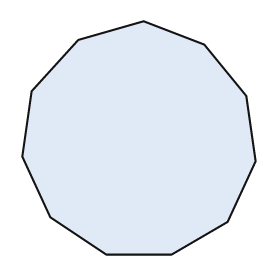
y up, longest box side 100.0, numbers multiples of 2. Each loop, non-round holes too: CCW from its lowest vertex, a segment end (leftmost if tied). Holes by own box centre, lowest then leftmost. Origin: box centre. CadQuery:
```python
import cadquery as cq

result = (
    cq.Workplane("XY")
    .moveTo(-14.0, -50.0)
    .lineTo(14.0, -50.0)
    .lineTo(38.0, -36.0)
    .lineTo(50.0, -10.0)
    .lineTo(46.0, 18.0)
    .lineTo(28.0, 40.0)
    .lineTo(2.0, 50.0)
    .lineTo(-26.0, 42.0)
    .lineTo(-46.0, 20.0)
    .lineTo(-50.0, -8.0)
    .lineTo(-38.0, -34.0)
    .close()
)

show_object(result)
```